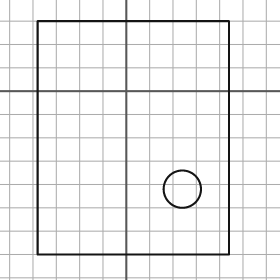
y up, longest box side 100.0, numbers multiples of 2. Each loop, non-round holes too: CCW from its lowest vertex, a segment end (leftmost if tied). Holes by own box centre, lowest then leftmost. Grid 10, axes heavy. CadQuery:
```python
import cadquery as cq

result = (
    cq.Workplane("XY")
    .moveTo(-38.0, -70.0)
    .lineTo(44.0, -70.0)
    .lineTo(44.0, 30.0)
    .lineTo(-38.0, 30.0)
    .close()
    .moveTo(24.0, -42.0)
    .circle(8.0)
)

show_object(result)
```